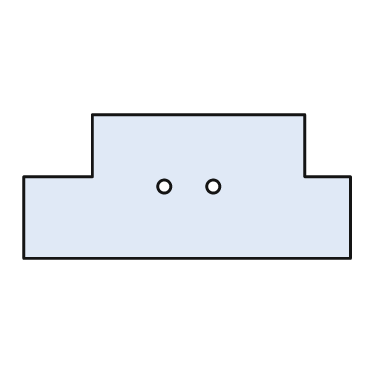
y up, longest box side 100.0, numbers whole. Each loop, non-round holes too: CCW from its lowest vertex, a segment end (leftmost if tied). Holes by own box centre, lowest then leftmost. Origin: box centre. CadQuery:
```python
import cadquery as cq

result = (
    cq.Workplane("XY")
    .moveTo(-50.0, -22.0)
    .lineTo(50.0, -22.0)
    .lineTo(50.0, 3.0)
    .lineTo(36.0, 3.0)
    .lineTo(36.0, 22.0)
    .lineTo(-29.0, 22.0)
    .lineTo(-29.0, 3.0)
    .lineTo(-50.0, 3.0)
    .close()
    .moveTo(-7.0, 0.0)
    .circle(2.0)
    .moveTo(8.0, 0.0)
    .circle(2.0)
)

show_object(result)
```